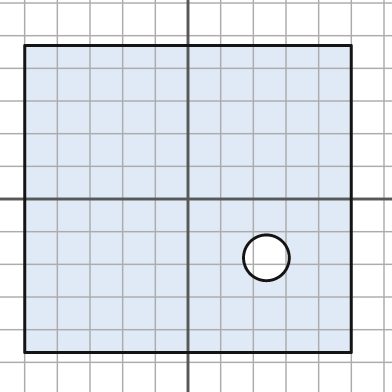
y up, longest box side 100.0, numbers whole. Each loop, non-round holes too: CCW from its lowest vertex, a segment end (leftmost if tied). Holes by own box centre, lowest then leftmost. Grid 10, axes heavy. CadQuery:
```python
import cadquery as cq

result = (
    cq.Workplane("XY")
    .moveTo(-50.0, -47.0)
    .lineTo(50.0, -47.0)
    .lineTo(50.0, 47.0)
    .lineTo(-50.0, 47.0)
    .close()
    .moveTo(24.0, -18.0)
    .circle(7.0)
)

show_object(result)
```